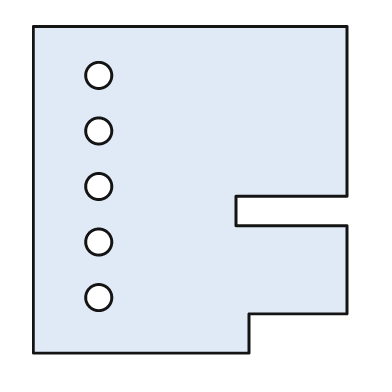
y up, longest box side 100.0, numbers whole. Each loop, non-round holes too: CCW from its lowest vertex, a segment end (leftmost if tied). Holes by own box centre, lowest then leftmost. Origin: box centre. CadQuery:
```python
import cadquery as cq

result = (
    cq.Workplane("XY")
    .moveTo(-48.0, -50.0)
    .lineTo(18.0, -50.0)
    .lineTo(18.0, -38.0)
    .lineTo(48.0, -38.0)
    .lineTo(48.0, -11.0)
    .lineTo(14.0, -11.0)
    .lineTo(14.0, -2.0)
    .lineTo(48.0, -2.0)
    .lineTo(48.0, 50.0)
    .lineTo(-48.0, 50.0)
    .close()
    .moveTo(-28.0, -33.0)
    .circle(4.0)
    .moveTo(-28.0, -16.0)
    .circle(4.0)
    .moveTo(-28.0, 1.0)
    .circle(4.0)
    .moveTo(-28.0, 18.0)
    .circle(4.0)
    .moveTo(-28.0, 35.0)
    .circle(4.0)
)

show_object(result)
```